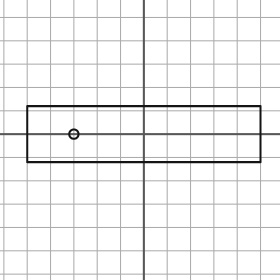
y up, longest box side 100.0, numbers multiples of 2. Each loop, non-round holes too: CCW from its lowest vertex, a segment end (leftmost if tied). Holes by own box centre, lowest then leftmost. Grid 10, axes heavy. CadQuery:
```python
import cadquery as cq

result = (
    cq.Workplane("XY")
    .moveTo(-50.0, -12.0)
    .lineTo(50.0, -12.0)
    .lineTo(50.0, 12.0)
    .lineTo(-50.0, 12.0)
    .close()
    .moveTo(-30.0, 0.0)
    .circle(2.0)
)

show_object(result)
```